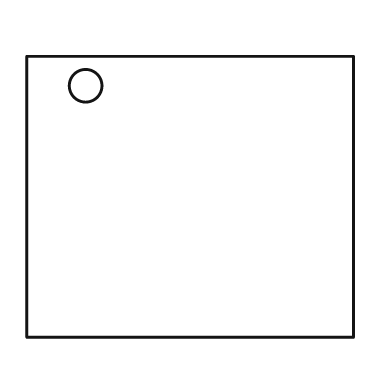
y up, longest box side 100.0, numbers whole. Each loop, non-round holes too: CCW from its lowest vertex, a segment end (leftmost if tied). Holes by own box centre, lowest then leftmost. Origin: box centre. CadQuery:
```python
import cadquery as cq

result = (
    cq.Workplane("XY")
    .moveTo(-50.0, -43.0)
    .lineTo(50.0, -43.0)
    .lineTo(50.0, 43.0)
    .lineTo(-50.0, 43.0)
    .close()
    .moveTo(-32.0, 34.0)
    .circle(5.0)
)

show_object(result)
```